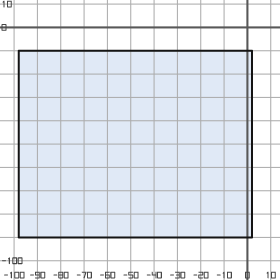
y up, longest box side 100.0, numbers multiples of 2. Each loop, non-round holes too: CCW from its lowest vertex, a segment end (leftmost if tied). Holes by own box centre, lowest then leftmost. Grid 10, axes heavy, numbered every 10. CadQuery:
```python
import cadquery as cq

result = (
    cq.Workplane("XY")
    .moveTo(-98.0, -90.0)
    .lineTo(2.0, -90.0)
    .lineTo(2.0, -10.0)
    .lineTo(-98.0, -10.0)
    .close()
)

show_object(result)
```